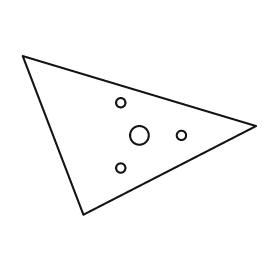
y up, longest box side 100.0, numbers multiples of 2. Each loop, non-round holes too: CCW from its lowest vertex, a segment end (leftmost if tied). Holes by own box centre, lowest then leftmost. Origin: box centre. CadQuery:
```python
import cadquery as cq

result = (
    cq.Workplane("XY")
    .moveTo(-24.0, -34.0)
    .lineTo(50.0, 4.0)
    .lineTo(-50.0, 34.0)
    .close()
    .moveTo(-8.0, -14.0)
    .circle(2.0)
    .moveTo(0.0, 0.0)
    .circle(4.0)
    .moveTo(18.0, 0.0)
    .circle(2.0)
    .moveTo(-8.0, 14.0)
    .circle(2.0)
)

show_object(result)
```